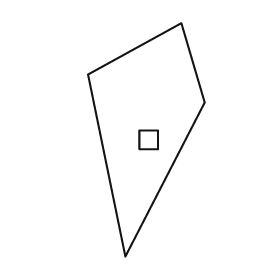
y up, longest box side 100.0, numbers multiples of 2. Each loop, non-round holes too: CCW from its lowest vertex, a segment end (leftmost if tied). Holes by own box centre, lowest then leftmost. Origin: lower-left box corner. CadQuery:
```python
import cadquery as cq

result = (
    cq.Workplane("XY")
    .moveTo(16.0, 0.0)
    .lineTo(50.0, 66.0)
    .lineTo(40.0, 100.0)
    .lineTo(0.0, 78.0)
    .close()
    .moveTo(22.0, 46.0)
    .lineTo(30.0, 46.0)
    .lineTo(30.0, 54.0)
    .lineTo(22.0, 54.0)
    .close()
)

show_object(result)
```